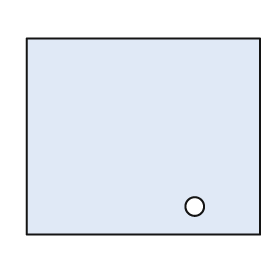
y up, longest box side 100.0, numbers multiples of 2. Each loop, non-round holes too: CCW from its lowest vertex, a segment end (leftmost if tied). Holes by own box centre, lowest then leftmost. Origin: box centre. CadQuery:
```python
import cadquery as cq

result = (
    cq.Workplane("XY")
    .moveTo(-50.0, -42.0)
    .lineTo(50.0, -42.0)
    .lineTo(50.0, 42.0)
    .lineTo(-50.0, 42.0)
    .close()
    .moveTo(22.0, -30.0)
    .circle(4.0)
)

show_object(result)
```